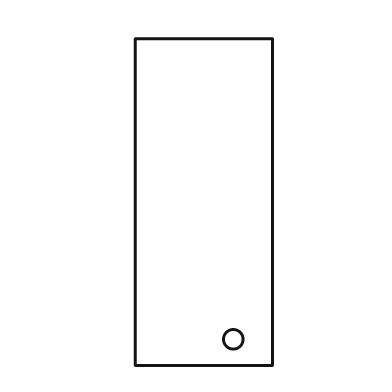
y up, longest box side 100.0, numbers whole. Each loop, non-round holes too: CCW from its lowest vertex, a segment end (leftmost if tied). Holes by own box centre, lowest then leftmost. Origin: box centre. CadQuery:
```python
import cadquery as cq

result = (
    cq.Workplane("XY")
    .moveTo(-21.0, -50.0)
    .lineTo(21.0, -50.0)
    .lineTo(21.0, 50.0)
    .lineTo(-21.0, 50.0)
    .close()
    .moveTo(9.0, -42.0)
    .circle(3.0)
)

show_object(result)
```